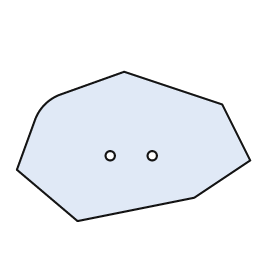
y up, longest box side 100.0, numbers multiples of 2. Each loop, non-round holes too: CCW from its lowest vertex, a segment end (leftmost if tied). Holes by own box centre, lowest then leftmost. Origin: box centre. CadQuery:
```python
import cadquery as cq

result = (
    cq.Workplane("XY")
    .moveTo(-24.0, -32.0)
    .lineTo(26.0, -22.0)
    .lineTo(50.0, -6.0)
    .lineTo(38.0, 18.0)
    .lineTo(-4.0, 32.0)
    .lineTo(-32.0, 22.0)
    .threePointArc((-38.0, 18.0), (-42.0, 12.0))
    .lineTo(-50.0, -10.0)
    .close()
    .moveTo(-10.0, -4.0)
    .circle(2.0)
    .moveTo(8.0, -4.0)
    .circle(2.0)
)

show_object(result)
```